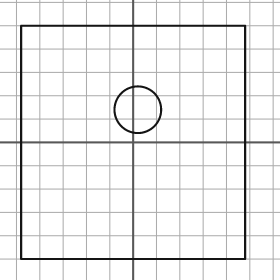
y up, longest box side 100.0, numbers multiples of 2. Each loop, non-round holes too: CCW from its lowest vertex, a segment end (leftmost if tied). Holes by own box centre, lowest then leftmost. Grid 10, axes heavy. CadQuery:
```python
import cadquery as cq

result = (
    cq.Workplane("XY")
    .moveTo(-48.0, -50.0)
    .lineTo(48.0, -50.0)
    .lineTo(48.0, 50.0)
    .lineTo(-48.0, 50.0)
    .close()
    .moveTo(2.0, 14.0)
    .circle(10.0)
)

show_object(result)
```